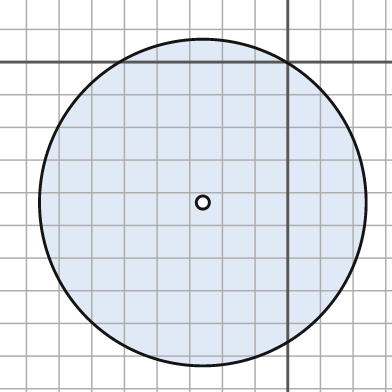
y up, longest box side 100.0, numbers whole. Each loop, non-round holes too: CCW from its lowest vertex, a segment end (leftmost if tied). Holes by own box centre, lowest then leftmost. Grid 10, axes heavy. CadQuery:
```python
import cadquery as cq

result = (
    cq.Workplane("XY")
    .moveTo(-26.0, -43.0)
    .circle(50.0)
    .moveTo(-26.0, -43.0)
    .circle(2.0)
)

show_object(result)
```